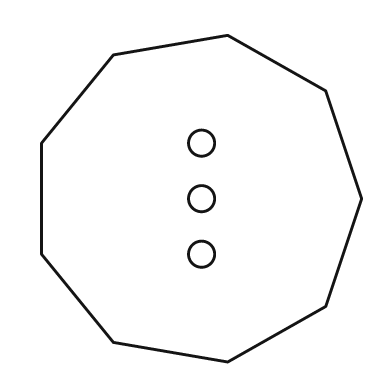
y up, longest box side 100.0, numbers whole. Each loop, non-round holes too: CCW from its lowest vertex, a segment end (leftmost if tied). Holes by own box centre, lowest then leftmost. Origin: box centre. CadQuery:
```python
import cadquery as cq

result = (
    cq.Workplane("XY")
    .moveTo(8.0, -50.0)
    .lineTo(38.0, -33.0)
    .lineTo(49.0, 0.0)
    .lineTo(38.0, 33.0)
    .lineTo(8.0, 50.0)
    .lineTo(-27.0, 44.0)
    .lineTo(-49.0, 17.0)
    .lineTo(-49.0, -17.0)
    .lineTo(-27.0, -44.0)
    .close()
    .moveTo(0.0, -17.0)
    .circle(4.0)
    .moveTo(0.0, 0.0)
    .circle(4.0)
    .moveTo(0.0, 17.0)
    .circle(4.0)
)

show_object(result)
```